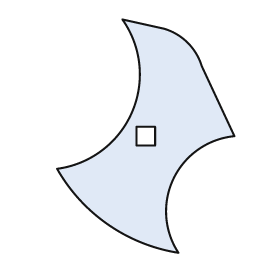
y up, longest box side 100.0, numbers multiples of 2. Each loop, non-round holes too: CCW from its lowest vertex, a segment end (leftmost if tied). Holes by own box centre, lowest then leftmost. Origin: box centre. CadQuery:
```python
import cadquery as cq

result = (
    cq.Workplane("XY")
    .moveTo(14.0, -50.0)
    .threePointArc((12.0, -18.0), (38.0, 0.0))
    .lineTo(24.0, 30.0)
    .threePointArc((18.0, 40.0), (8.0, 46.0))
    .lineTo(-10.0, 50.0)
    .threePointArc((-6.0, 10.0), (-38.0, -14.0))
    .threePointArc((-16.0, -38.0), (14.0, -50.0))
    .close()
    .moveTo(-4.0, -4.0)
    .lineTo(4.0, -4.0)
    .lineTo(4.0, 4.0)
    .lineTo(-4.0, 4.0)
    .close()
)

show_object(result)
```